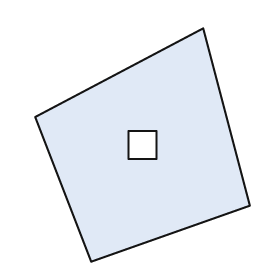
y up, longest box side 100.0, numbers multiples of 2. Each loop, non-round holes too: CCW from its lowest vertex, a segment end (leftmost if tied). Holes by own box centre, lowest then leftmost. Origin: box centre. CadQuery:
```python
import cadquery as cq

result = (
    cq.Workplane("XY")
    .moveTo(-22.0, -50.0)
    .lineTo(46.0, -26.0)
    .lineTo(26.0, 50.0)
    .lineTo(-46.0, 12.0)
    .close()
    .moveTo(-6.0, -6.0)
    .lineTo(6.0, -6.0)
    .lineTo(6.0, 6.0)
    .lineTo(-6.0, 6.0)
    .close()
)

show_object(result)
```